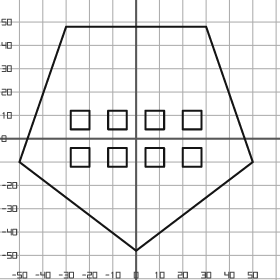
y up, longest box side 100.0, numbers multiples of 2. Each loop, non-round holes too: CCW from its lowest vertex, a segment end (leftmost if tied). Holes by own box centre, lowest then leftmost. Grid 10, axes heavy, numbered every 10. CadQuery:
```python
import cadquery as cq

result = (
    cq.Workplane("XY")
    .moveTo(0.0, -48.0)
    .lineTo(50.0, -10.0)
    .lineTo(30.0, 48.0)
    .lineTo(-30.0, 48.0)
    .lineTo(-50.0, -10.0)
    .close()
    .moveTo(-28.0, -12.0)
    .lineTo(-20.0, -12.0)
    .lineTo(-20.0, -4.0)
    .lineTo(-28.0, -4.0)
    .close()
    .moveTo(-12.0, -12.0)
    .lineTo(-4.0, -12.0)
    .lineTo(-4.0, -4.0)
    .lineTo(-12.0, -4.0)
    .close()
    .moveTo(4.0, -12.0)
    .lineTo(12.0, -12.0)
    .lineTo(12.0, -4.0)
    .lineTo(4.0, -4.0)
    .close()
    .moveTo(20.0, -12.0)
    .lineTo(28.0, -12.0)
    .lineTo(28.0, -4.0)
    .lineTo(20.0, -4.0)
    .close()
    .moveTo(-28.0, 4.0)
    .lineTo(-20.0, 4.0)
    .lineTo(-20.0, 12.0)
    .lineTo(-28.0, 12.0)
    .close()
    .moveTo(-12.0, 4.0)
    .lineTo(-4.0, 4.0)
    .lineTo(-4.0, 12.0)
    .lineTo(-12.0, 12.0)
    .close()
    .moveTo(4.0, 4.0)
    .lineTo(12.0, 4.0)
    .lineTo(12.0, 12.0)
    .lineTo(4.0, 12.0)
    .close()
    .moveTo(20.0, 4.0)
    .lineTo(28.0, 4.0)
    .lineTo(28.0, 12.0)
    .lineTo(20.0, 12.0)
    .close()
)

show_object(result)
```